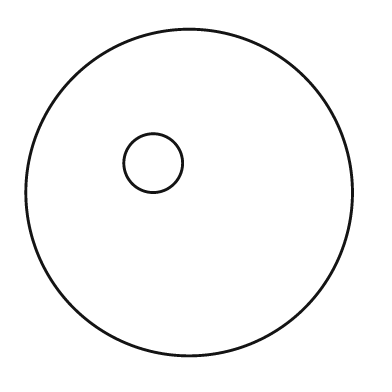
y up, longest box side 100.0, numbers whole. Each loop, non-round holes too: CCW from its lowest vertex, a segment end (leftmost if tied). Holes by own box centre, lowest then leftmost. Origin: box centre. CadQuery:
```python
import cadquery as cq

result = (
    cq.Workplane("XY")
    .moveTo(0.0, 0.0)
    .circle(50.0)
    .moveTo(-11.0, 9.0)
    .circle(9.0)
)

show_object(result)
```